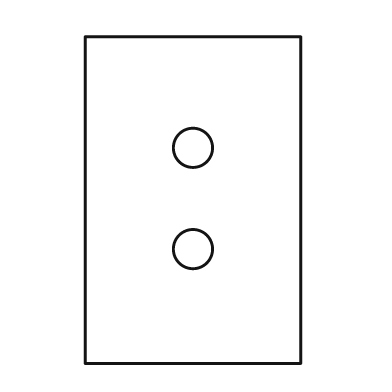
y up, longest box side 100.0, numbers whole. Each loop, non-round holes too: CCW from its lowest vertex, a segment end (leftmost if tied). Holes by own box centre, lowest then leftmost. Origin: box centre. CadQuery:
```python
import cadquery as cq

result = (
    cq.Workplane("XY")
    .moveTo(-33.0, -50.0)
    .lineTo(33.0, -50.0)
    .lineTo(33.0, 50.0)
    .lineTo(-33.0, 50.0)
    .close()
    .moveTo(0.0, -15.0)
    .circle(6.0)
    .moveTo(0.0, 16.0)
    .circle(6.0)
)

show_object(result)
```